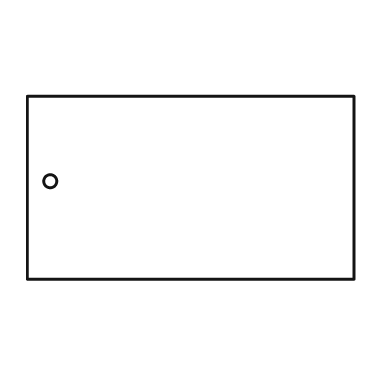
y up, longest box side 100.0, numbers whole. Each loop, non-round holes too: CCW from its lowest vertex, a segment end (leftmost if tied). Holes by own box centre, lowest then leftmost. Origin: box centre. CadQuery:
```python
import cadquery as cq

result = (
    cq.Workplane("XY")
    .moveTo(-50.0, -28.0)
    .lineTo(50.0, -28.0)
    .lineTo(50.0, 28.0)
    .lineTo(-50.0, 28.0)
    .close()
    .moveTo(-43.0, 2.0)
    .circle(2.0)
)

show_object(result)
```